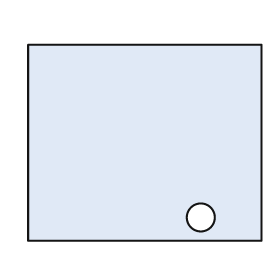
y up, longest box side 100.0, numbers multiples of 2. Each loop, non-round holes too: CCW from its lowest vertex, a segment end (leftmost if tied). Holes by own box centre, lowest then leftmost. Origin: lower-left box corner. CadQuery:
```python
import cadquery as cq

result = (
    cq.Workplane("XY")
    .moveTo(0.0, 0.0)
    .lineTo(100.0, 0.0)
    .lineTo(100.0, 84.0)
    .lineTo(0.0, 84.0)
    .close()
    .moveTo(74.0, 10.0)
    .circle(6.0)
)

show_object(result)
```